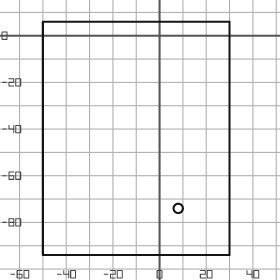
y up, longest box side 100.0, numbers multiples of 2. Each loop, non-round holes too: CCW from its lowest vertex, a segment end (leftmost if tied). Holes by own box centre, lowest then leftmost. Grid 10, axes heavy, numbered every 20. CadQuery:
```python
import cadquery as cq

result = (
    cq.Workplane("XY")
    .moveTo(-50.0, -94.0)
    .lineTo(30.0, -94.0)
    .lineTo(30.0, 6.0)
    .lineTo(-50.0, 6.0)
    .close()
    .moveTo(8.0, -74.0)
    .circle(2.0)
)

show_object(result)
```